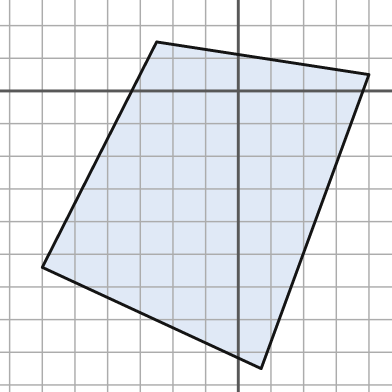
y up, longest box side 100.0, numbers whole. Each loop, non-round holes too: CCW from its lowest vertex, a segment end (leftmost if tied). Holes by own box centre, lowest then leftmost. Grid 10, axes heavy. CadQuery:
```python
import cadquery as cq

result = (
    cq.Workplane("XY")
    .moveTo(7.0, -85.0)
    .lineTo(40.0, 5.0)
    .lineTo(-25.0, 15.0)
    .lineTo(-60.0, -54.0)
    .close()
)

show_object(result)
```